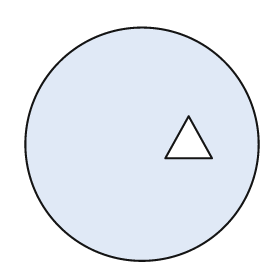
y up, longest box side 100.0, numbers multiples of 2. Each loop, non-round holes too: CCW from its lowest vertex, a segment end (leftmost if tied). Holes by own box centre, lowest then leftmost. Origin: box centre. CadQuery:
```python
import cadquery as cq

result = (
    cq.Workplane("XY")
    .moveTo(0.0, 0.0)
    .circle(50.0)
    .moveTo(10.0, -6.0)
    .lineTo(30.0, -6.0)
    .lineTo(20.0, 12.0)
    .close()
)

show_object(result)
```